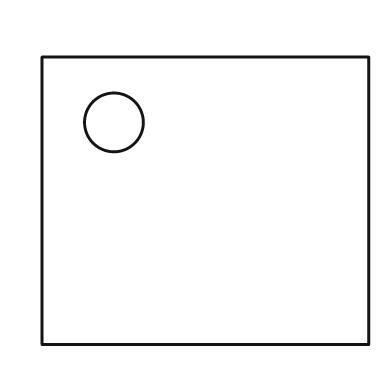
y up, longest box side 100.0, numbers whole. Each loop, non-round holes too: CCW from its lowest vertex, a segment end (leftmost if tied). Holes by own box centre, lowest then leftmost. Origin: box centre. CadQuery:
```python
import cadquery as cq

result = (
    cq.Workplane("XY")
    .moveTo(-50.0, -44.0)
    .lineTo(50.0, -44.0)
    .lineTo(50.0, 44.0)
    .lineTo(-50.0, 44.0)
    .close()
    .moveTo(-28.0, 24.0)
    .circle(9.0)
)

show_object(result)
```